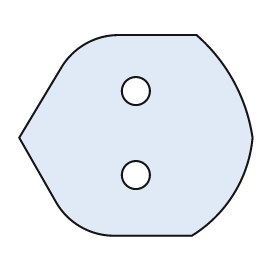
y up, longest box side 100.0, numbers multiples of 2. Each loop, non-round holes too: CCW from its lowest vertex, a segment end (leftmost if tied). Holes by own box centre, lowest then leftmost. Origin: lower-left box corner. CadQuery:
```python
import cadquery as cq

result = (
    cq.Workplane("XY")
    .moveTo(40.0, 0.0)
    .lineTo(74.0, 0.0)
    .threePointArc((92.0, 18.0), (100.0, 42.0))
    .threePointArc((92.0, 66.0), (76.0, 86.0))
    .lineTo(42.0, 86.0)
    .threePointArc((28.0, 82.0), (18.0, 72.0))
    .lineTo(0.0, 42.0)
    .lineTo(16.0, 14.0)
    .threePointArc((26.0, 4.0), (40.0, 0.0))
    .close()
    .moveTo(50.0, 26.0)
    .circle(6.0)
    .moveTo(50.0, 62.0)
    .circle(6.0)
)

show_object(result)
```